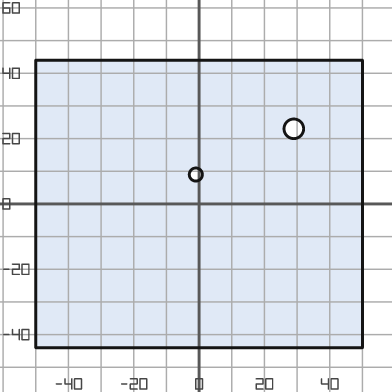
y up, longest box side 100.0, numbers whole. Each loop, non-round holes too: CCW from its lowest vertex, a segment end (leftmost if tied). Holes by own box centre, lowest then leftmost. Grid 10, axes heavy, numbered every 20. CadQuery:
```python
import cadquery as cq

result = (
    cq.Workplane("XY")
    .moveTo(-50.0, -44.0)
    .lineTo(50.0, -44.0)
    .lineTo(50.0, 44.0)
    .lineTo(-50.0, 44.0)
    .close()
    .moveTo(-1.0, 9.0)
    .circle(2.0)
    .moveTo(29.0, 23.0)
    .circle(3.0)
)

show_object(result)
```